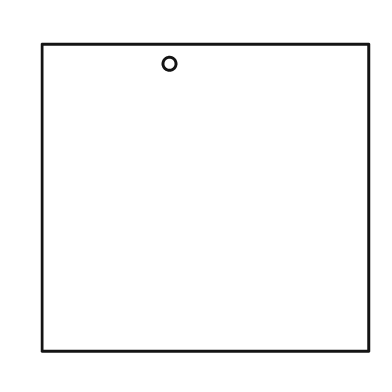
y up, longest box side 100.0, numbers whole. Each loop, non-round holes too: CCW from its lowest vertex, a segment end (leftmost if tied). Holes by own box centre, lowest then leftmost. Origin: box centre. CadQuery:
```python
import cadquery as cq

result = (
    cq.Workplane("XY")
    .moveTo(-50.0, -47.0)
    .lineTo(50.0, -47.0)
    .lineTo(50.0, 47.0)
    .lineTo(-50.0, 47.0)
    .close()
    .moveTo(-11.0, 41.0)
    .circle(2.0)
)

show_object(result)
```